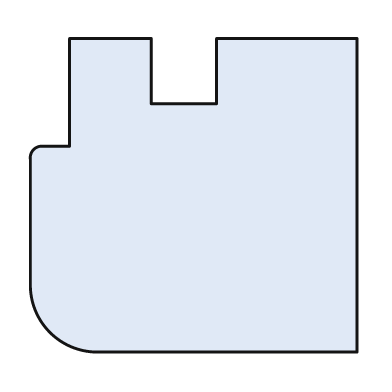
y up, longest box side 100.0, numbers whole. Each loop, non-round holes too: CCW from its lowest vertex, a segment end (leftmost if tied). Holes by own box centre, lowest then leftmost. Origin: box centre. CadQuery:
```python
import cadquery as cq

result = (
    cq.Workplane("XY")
    .moveTo(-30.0, -48.0)
    .lineTo(50.0, -48.0)
    .lineTo(50.0, 48.0)
    .lineTo(7.0, 48.0)
    .lineTo(7.0, 28.0)
    .lineTo(-13.0, 28.0)
    .lineTo(-13.0, 48.0)
    .lineTo(-38.0, 48.0)
    .lineTo(-38.0, 15.0)
    .lineTo(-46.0, 15.0)
    .threePointArc((-49.0, 14.0), (-50.0, 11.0))
    .lineTo(-50.0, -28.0)
    .threePointArc((-44.0, -42.0), (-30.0, -48.0))
    .close()
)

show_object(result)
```